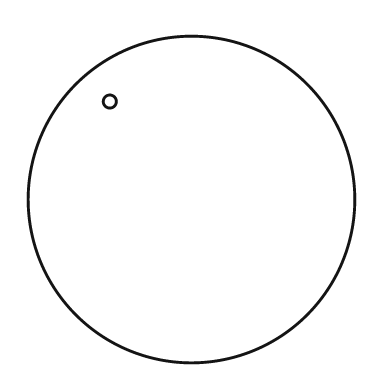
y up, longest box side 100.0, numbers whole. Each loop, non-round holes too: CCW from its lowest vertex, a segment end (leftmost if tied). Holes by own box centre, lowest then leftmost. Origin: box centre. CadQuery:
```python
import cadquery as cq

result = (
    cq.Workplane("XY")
    .moveTo(0.0, 0.0)
    .circle(50.0)
    .moveTo(-25.0, 30.0)
    .circle(2.0)
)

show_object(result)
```